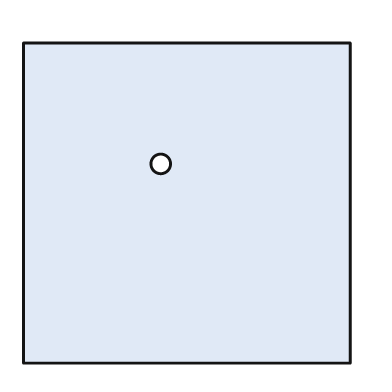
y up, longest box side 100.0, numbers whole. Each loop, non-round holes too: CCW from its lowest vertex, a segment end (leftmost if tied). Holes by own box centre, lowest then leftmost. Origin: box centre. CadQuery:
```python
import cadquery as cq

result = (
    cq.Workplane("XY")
    .moveTo(-50.0, -49.0)
    .lineTo(50.0, -49.0)
    .lineTo(50.0, 49.0)
    .lineTo(-50.0, 49.0)
    .close()
    .moveTo(-8.0, 12.0)
    .circle(3.0)
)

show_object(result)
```